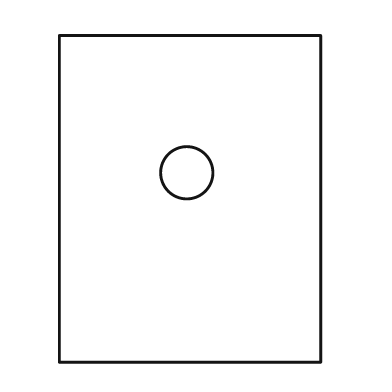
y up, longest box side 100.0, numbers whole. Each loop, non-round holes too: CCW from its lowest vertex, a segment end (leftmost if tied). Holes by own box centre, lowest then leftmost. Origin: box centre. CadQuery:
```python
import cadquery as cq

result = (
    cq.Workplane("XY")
    .moveTo(-40.0, -50.0)
    .lineTo(40.0, -50.0)
    .lineTo(40.0, 50.0)
    .lineTo(-40.0, 50.0)
    .close()
    .moveTo(-1.0, 8.0)
    .circle(8.0)
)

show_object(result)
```